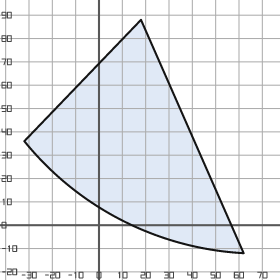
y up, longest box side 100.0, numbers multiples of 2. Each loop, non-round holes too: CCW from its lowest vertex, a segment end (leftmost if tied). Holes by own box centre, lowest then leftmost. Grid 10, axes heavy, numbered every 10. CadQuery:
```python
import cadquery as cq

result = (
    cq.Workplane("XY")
    .moveTo(62.0, -12.0)
    .lineTo(18.0, 88.0)
    .lineTo(-32.0, 36.0)
    .threePointArc((10.0, 2.0), (62.0, -12.0))
    .close()
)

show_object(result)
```